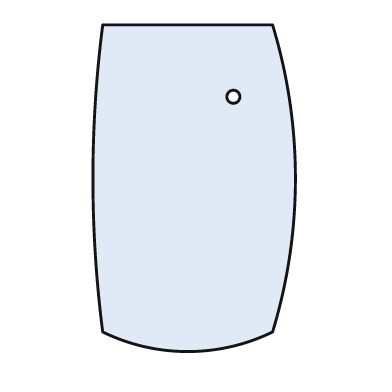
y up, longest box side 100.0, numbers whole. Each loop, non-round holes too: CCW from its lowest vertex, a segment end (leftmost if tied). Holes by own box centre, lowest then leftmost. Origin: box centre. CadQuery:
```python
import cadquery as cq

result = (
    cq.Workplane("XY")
    .moveTo(-28.0, -44.0)
    .threePointArc((-2.0, -50.0), (24.0, -44.0))
    .threePointArc((31.0, 3.0), (24.0, 50.0))
    .lineTo(-28.0, 50.0)
    .threePointArc((-31.0, 3.0), (-28.0, -44.0))
    .close()
    .moveTo(12.0, 28.0)
    .circle(2.0)
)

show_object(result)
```